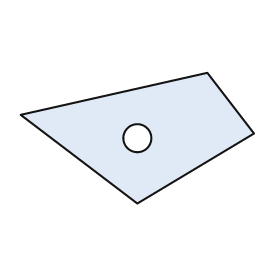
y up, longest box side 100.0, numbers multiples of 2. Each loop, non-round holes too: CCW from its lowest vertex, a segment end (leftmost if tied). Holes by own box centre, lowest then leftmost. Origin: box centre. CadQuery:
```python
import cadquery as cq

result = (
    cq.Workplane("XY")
    .moveTo(0.0, -28.0)
    .lineTo(50.0, 2.0)
    .lineTo(30.0, 28.0)
    .lineTo(-50.0, 10.0)
    .close()
    .moveTo(0.0, 0.0)
    .circle(6.0)
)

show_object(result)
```